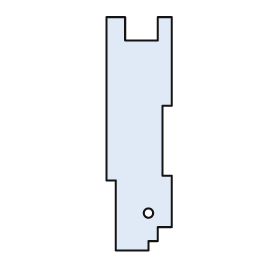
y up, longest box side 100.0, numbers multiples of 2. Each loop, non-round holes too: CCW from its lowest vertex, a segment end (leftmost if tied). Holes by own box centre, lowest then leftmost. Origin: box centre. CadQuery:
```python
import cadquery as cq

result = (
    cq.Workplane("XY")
    .moveTo(-10.0, -50.0)
    .lineTo(4.0, -50.0)
    .lineTo(4.0, -46.0)
    .lineTo(8.0, -46.0)
    .lineTo(8.0, -40.0)
    .lineTo(14.0, -40.0)
    .lineTo(14.0, -18.0)
    .lineTo(10.0, -18.0)
    .lineTo(10.0, 12.0)
    .lineTo(14.0, 12.0)
    .lineTo(14.0, 50.0)
    .lineTo(8.0, 50.0)
    .lineTo(8.0, 40.0)
    .lineTo(-6.0, 40.0)
    .lineTo(-6.0, 50.0)
    .lineTo(-14.0, 50.0)
    .lineTo(-14.0, -20.0)
    .lineTo(-10.0, -20.0)
    .close()
    .moveTo(4.0, -34.0)
    .circle(2.0)
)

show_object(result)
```